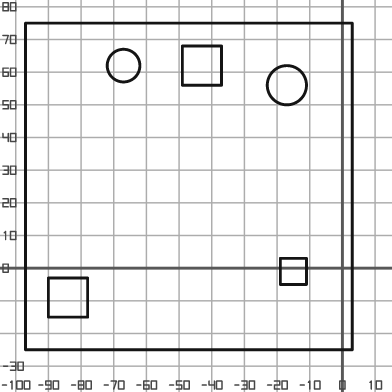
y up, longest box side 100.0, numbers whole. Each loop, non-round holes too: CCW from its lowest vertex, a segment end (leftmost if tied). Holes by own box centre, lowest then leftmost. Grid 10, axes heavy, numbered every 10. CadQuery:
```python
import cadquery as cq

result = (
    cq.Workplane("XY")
    .moveTo(-97.0, -25.0)
    .lineTo(3.0, -25.0)
    .lineTo(3.0, 75.0)
    .lineTo(-97.0, 75.0)
    .close()
    .moveTo(-90.0, -15.0)
    .lineTo(-78.0, -15.0)
    .lineTo(-78.0, -3.0)
    .lineTo(-90.0, -3.0)
    .close()
    .moveTo(-19.0, -5.0)
    .lineTo(-11.0, -5.0)
    .lineTo(-11.0, 3.0)
    .lineTo(-19.0, 3.0)
    .close()
    .moveTo(-17.0, 56.0)
    .circle(6.0)
    .moveTo(-67.0, 62.0)
    .circle(5.0)
    .moveTo(-49.0, 56.0)
    .lineTo(-37.0, 56.0)
    .lineTo(-37.0, 68.0)
    .lineTo(-49.0, 68.0)
    .close()
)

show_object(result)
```